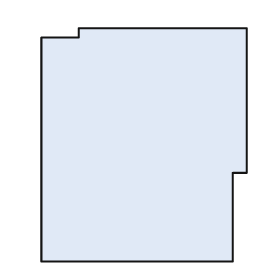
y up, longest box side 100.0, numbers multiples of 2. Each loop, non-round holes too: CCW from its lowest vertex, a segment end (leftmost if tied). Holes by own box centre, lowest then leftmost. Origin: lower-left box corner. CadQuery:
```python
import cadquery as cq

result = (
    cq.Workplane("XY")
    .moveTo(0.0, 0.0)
    .lineTo(82.0, 0.0)
    .lineTo(82.0, 38.0)
    .lineTo(88.0, 38.0)
    .lineTo(88.0, 100.0)
    .lineTo(16.0, 100.0)
    .lineTo(16.0, 96.0)
    .lineTo(0.0, 96.0)
    .close()
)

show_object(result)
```